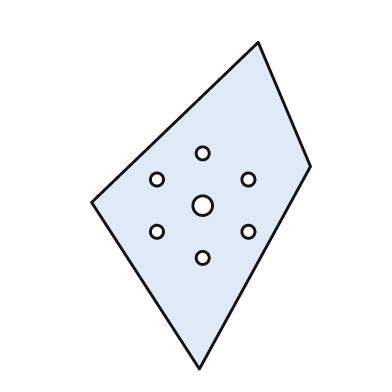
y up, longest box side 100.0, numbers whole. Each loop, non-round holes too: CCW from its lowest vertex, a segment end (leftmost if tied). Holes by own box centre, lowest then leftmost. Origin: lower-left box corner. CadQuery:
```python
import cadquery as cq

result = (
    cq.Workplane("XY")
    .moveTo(33.0, 0.0)
    .lineTo(67.0, 62.0)
    .lineTo(51.0, 100.0)
    .lineTo(0.0, 51.0)
    .close()
    .moveTo(34.0, 34.0)
    .circle(2.0)
    .moveTo(20.0, 42.0)
    .circle(2.0)
    .moveTo(48.0, 42.0)
    .circle(2.0)
    .moveTo(34.0, 50.0)
    .circle(3.0)
    .moveTo(20.0, 58.0)
    .circle(2.0)
    .moveTo(48.0, 58.0)
    .circle(2.0)
    .moveTo(34.0, 66.0)
    .circle(2.0)
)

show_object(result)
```